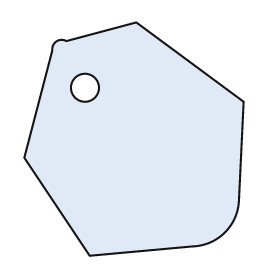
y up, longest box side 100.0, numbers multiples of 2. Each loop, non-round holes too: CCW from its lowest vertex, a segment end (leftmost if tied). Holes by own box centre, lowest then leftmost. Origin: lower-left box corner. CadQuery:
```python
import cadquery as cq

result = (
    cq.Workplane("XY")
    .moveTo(28.0, 0.0)
    .lineTo(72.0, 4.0)
    .threePointArc((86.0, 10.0), (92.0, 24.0))
    .lineTo(94.0, 66.0)
    .lineTo(48.0, 100.0)
    .lineTo(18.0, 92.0)
    .threePointArc((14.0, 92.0), (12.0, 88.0))
    .lineTo(0.0, 42.0)
    .close()
    .moveTo(26.0, 72.0)
    .circle(6.0)
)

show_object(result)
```